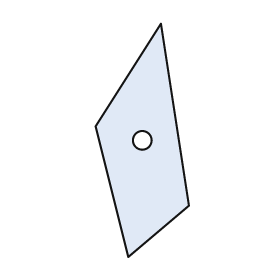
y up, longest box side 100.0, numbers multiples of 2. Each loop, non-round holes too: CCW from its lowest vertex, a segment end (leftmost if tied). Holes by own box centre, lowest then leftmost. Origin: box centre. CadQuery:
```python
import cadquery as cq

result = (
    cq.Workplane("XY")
    .moveTo(-6.0, -50.0)
    .lineTo(20.0, -28.0)
    .lineTo(8.0, 50.0)
    .lineTo(-20.0, 6.0)
    .close()
    .moveTo(0.0, 0.0)
    .circle(4.0)
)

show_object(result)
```